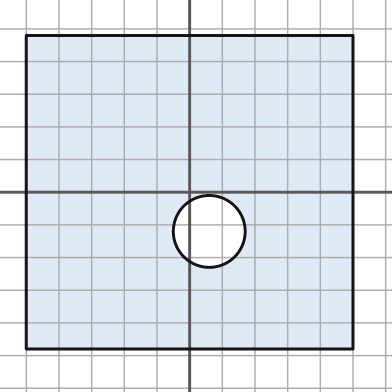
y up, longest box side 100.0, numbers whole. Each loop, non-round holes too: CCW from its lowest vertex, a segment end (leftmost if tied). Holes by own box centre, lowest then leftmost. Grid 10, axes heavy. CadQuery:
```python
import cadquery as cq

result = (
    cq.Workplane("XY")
    .moveTo(-50.0, -48.0)
    .lineTo(50.0, -48.0)
    .lineTo(50.0, 48.0)
    .lineTo(-50.0, 48.0)
    .close()
    .moveTo(6.0, -12.0)
    .circle(11.0)
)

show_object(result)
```